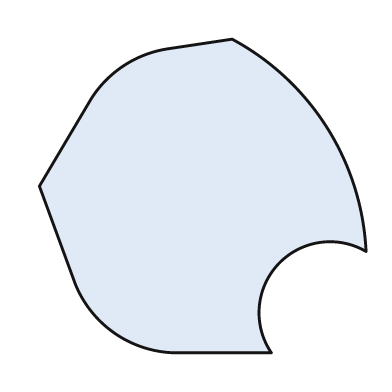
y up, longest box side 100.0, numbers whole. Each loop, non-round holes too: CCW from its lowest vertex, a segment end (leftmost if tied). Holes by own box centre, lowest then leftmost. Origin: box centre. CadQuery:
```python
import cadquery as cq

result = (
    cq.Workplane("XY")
    .moveTo(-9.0, -48.0)
    .lineTo(21.0, -48.0)
    .threePointArc((23.0, -21.0), (50.0, -17.0))
    .threePointArc((38.0, 21.0), (9.0, 48.0))
    .lineTo(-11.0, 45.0)
    .threePointArc((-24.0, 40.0), (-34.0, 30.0))
    .lineTo(-50.0, 3.0)
    .lineTo(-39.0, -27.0)
    .threePointArc((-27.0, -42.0), (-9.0, -48.0))
    .close()
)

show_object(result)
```